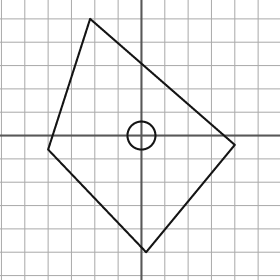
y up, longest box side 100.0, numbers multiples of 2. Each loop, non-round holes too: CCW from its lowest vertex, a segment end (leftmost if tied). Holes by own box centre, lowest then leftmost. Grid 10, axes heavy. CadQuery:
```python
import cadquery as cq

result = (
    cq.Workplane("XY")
    .moveTo(2.0, -50.0)
    .lineTo(40.0, -4.0)
    .lineTo(-22.0, 50.0)
    .lineTo(-40.0, -6.0)
    .close()
    .moveTo(0.0, 0.0)
    .circle(6.0)
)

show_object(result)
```